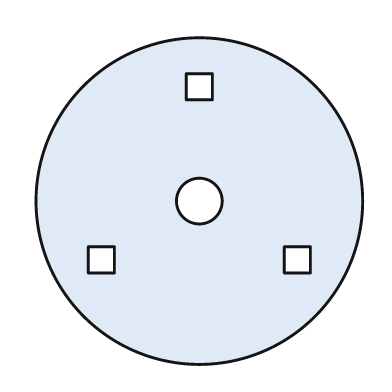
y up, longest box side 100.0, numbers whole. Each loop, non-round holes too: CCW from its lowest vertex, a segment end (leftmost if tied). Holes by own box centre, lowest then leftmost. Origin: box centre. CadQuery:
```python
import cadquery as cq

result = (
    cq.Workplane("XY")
    .moveTo(0.0, 0.0)
    .circle(50.0)
    .moveTo(-34.0, -22.0)
    .lineTo(-26.0, -22.0)
    .lineTo(-26.0, -14.0)
    .lineTo(-34.0, -14.0)
    .close()
    .moveTo(26.0, -22.0)
    .lineTo(34.0, -22.0)
    .lineTo(34.0, -14.0)
    .lineTo(26.0, -14.0)
    .close()
    .moveTo(0.0, 0.0)
    .circle(7.0)
    .moveTo(-4.0, 31.0)
    .lineTo(4.0, 31.0)
    .lineTo(4.0, 39.0)
    .lineTo(-4.0, 39.0)
    .close()
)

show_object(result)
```